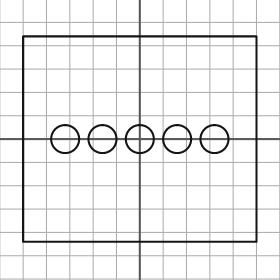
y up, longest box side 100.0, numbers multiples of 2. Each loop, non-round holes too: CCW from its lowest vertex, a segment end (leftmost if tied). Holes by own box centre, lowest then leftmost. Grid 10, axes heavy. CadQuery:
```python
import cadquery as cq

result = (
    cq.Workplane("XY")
    .moveTo(-50.0, -44.0)
    .lineTo(50.0, -44.0)
    .lineTo(50.0, 44.0)
    .lineTo(-50.0, 44.0)
    .close()
    .moveTo(-32.0, 0.0)
    .circle(6.0)
    .moveTo(-16.0, 0.0)
    .circle(6.0)
    .moveTo(0.0, 0.0)
    .circle(6.0)
    .moveTo(16.0, 0.0)
    .circle(6.0)
    .moveTo(32.0, 0.0)
    .circle(6.0)
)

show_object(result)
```